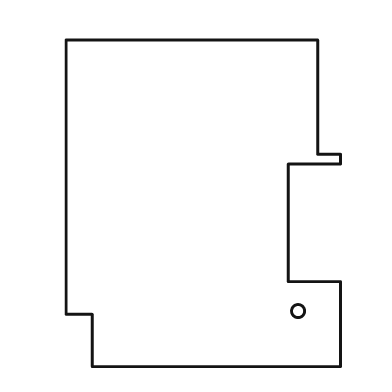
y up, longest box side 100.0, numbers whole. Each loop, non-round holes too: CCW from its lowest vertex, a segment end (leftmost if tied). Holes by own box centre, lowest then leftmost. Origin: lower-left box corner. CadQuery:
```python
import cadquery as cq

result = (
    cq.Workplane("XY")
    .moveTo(8.0, 0.0)
    .lineTo(84.0, 0.0)
    .lineTo(84.0, 26.0)
    .lineTo(68.0, 26.0)
    .lineTo(68.0, 62.0)
    .lineTo(84.0, 62.0)
    .lineTo(84.0, 65.0)
    .lineTo(77.0, 65.0)
    .lineTo(77.0, 100.0)
    .lineTo(0.0, 100.0)
    .lineTo(0.0, 16.0)
    .lineTo(8.0, 16.0)
    .close()
    .moveTo(71.0, 17.0)
    .circle(2.0)
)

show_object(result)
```